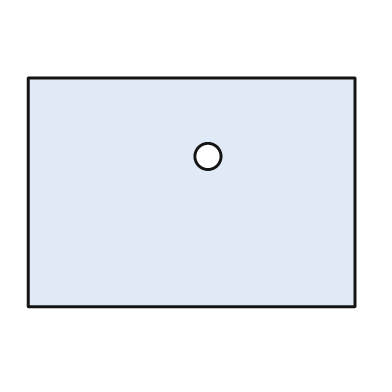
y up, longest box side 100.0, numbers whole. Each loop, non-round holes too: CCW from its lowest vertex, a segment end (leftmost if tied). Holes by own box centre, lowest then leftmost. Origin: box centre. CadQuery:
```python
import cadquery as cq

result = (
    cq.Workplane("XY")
    .moveTo(-50.0, -35.0)
    .lineTo(50.0, -35.0)
    .lineTo(50.0, 35.0)
    .lineTo(-50.0, 35.0)
    .close()
    .moveTo(5.0, 11.0)
    .circle(4.0)
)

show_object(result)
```